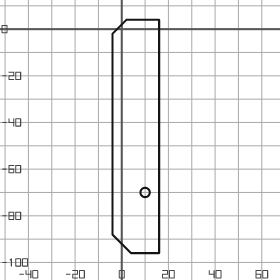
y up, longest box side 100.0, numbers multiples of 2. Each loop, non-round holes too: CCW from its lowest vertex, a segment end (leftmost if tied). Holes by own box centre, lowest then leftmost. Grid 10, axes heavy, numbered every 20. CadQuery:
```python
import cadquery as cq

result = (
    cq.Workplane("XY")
    .moveTo(4.0, -96.0)
    .lineTo(16.0, -96.0)
    .lineTo(16.0, 4.0)
    .lineTo(2.0, 4.0)
    .lineTo(-4.0, -2.0)
    .lineTo(-4.0, -88.0)
    .close()
    .moveTo(10.0, -70.0)
    .circle(2.0)
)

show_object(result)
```